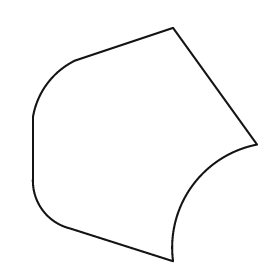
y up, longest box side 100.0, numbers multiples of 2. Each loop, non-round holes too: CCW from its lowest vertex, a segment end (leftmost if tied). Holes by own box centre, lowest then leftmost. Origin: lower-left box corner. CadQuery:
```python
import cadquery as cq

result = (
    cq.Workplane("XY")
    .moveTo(60.0, 0.0)
    .threePointArc((68.0, 32.0), (96.0, 50.0))
    .lineTo(60.0, 100.0)
    .lineTo(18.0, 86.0)
    .threePointArc((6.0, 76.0), (0.0, 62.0))
    .lineTo(0.0, 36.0)
    .threePointArc((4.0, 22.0), (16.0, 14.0))
    .close()
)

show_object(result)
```